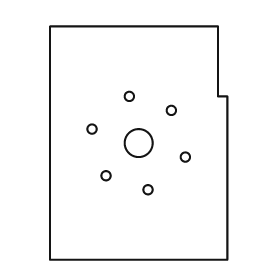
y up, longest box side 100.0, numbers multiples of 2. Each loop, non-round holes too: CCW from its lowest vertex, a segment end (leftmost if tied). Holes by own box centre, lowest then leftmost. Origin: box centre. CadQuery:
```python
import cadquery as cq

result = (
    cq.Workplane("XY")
    .moveTo(-38.0, -50.0)
    .lineTo(38.0, -50.0)
    .lineTo(38.0, 20.0)
    .lineTo(34.0, 20.0)
    .lineTo(34.0, 50.0)
    .lineTo(-38.0, 50.0)
    .close()
    .moveTo(4.0, -20.0)
    .circle(2.0)
    .moveTo(-14.0, -14.0)
    .circle(2.0)
    .moveTo(20.0, -6.0)
    .circle(2.0)
    .moveTo(0.0, 0.0)
    .circle(6.0)
    .moveTo(-20.0, 6.0)
    .circle(2.0)
    .moveTo(14.0, 14.0)
    .circle(2.0)
    .moveTo(-4.0, 20.0)
    .circle(2.0)
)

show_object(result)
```